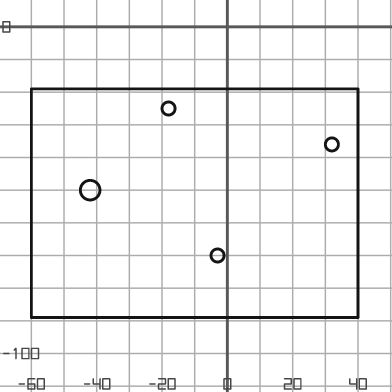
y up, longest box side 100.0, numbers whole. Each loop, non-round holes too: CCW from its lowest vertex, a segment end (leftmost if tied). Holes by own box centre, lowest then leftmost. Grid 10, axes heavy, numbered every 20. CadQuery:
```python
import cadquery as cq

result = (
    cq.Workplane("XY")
    .moveTo(-60.0, -89.0)
    .lineTo(40.0, -89.0)
    .lineTo(40.0, -19.0)
    .lineTo(-60.0, -19.0)
    .close()
    .moveTo(-3.0, -70.0)
    .circle(2.0)
    .moveTo(-42.0, -50.0)
    .circle(3.0)
    .moveTo(32.0, -36.0)
    .circle(2.0)
    .moveTo(-18.0, -25.0)
    .circle(2.0)
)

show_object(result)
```